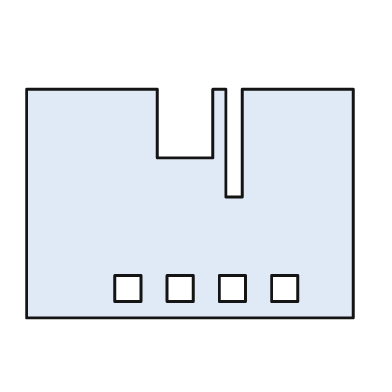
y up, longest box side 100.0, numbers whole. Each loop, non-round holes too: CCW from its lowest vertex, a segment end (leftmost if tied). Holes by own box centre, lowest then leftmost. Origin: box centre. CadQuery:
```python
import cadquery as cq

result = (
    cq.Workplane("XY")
    .moveTo(-50.0, -35.0)
    .lineTo(50.0, -35.0)
    .lineTo(50.0, 35.0)
    .lineTo(16.0, 35.0)
    .lineTo(16.0, 2.0)
    .lineTo(11.0, 2.0)
    .lineTo(11.0, 35.0)
    .lineTo(7.0, 35.0)
    .lineTo(7.0, 14.0)
    .lineTo(-10.0, 14.0)
    .lineTo(-10.0, 35.0)
    .lineTo(-50.0, 35.0)
    .close()
    .moveTo(-23.0, -30.0)
    .lineTo(-15.0, -30.0)
    .lineTo(-15.0, -22.0)
    .lineTo(-23.0, -22.0)
    .close()
    .moveTo(-7.0, -30.0)
    .lineTo(1.0, -30.0)
    .lineTo(1.0, -22.0)
    .lineTo(-7.0, -22.0)
    .close()
    .moveTo(9.0, -30.0)
    .lineTo(17.0, -30.0)
    .lineTo(17.0, -22.0)
    .lineTo(9.0, -22.0)
    .close()
    .moveTo(25.0, -30.0)
    .lineTo(33.0, -30.0)
    .lineTo(33.0, -22.0)
    .lineTo(25.0, -22.0)
    .close()
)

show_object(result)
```